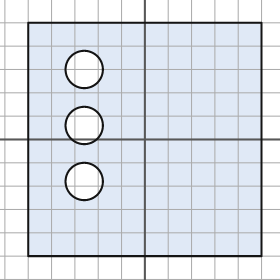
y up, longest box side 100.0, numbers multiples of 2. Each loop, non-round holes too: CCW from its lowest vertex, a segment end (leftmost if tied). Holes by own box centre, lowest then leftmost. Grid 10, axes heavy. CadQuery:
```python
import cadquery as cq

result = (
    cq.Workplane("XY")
    .moveTo(-50.0, -50.0)
    .lineTo(50.0, -50.0)
    .lineTo(50.0, 50.0)
    .lineTo(-50.0, 50.0)
    .close()
    .moveTo(-26.0, -18.0)
    .circle(8.0)
    .moveTo(-26.0, 6.0)
    .circle(8.0)
    .moveTo(-26.0, 30.0)
    .circle(8.0)
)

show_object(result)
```